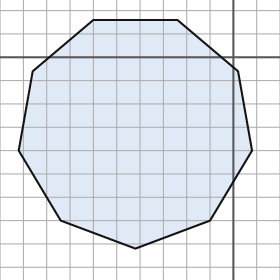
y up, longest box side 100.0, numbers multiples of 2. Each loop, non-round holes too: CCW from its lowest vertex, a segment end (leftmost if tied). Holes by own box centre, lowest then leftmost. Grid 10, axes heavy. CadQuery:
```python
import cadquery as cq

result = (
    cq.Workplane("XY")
    .moveTo(-42.0, -82.0)
    .lineTo(-10.0, -70.0)
    .lineTo(8.0, -40.0)
    .lineTo(2.0, -6.0)
    .lineTo(-24.0, 16.0)
    .lineTo(-60.0, 16.0)
    .lineTo(-86.0, -6.0)
    .lineTo(-92.0, -40.0)
    .lineTo(-74.0, -70.0)
    .close()
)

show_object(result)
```